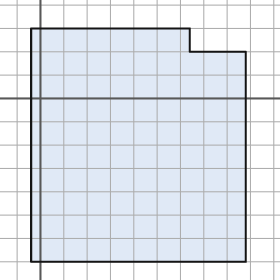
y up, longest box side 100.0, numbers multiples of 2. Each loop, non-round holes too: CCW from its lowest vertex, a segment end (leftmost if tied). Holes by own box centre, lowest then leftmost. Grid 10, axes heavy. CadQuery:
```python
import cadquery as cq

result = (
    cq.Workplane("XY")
    .moveTo(-4.0, -70.0)
    .lineTo(88.0, -70.0)
    .lineTo(88.0, 20.0)
    .lineTo(64.0, 20.0)
    .lineTo(64.0, 30.0)
    .lineTo(-4.0, 30.0)
    .close()
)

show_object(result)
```